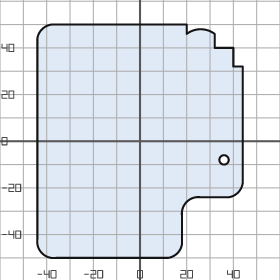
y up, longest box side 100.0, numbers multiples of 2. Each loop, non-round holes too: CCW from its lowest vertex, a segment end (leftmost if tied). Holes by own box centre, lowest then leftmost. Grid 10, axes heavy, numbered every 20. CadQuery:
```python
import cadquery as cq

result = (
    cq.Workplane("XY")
    .moveTo(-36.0, -50.0)
    .lineTo(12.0, -50.0)
    .threePointArc((16.0, -48.0), (18.0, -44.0))
    .lineTo(18.0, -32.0)
    .threePointArc((20.0, -26.0), (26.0, -24.0))
    .lineTo(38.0, -24.0)
    .threePointArc((42.0, -22.0), (44.0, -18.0))
    .lineTo(44.0, 32.0)
    .lineTo(40.0, 32.0)
    .lineTo(40.0, 40.0)
    .lineTo(32.0, 40.0)
    .lineTo(32.0, 46.0)
    .threePointArc((26.0, 48.0), (20.0, 46.0))
    .lineTo(20.0, 50.0)
    .lineTo(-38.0, 50.0)
    .threePointArc((-42.0, 48.0), (-44.0, 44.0))
    .lineTo(-44.0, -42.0)
    .threePointArc((-42.0, -48.0), (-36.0, -50.0))
    .close()
    .moveTo(36.0, -8.0)
    .circle(2.0)
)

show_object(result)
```